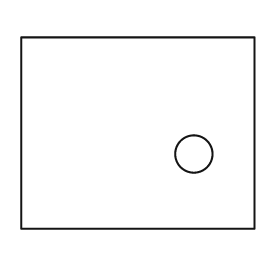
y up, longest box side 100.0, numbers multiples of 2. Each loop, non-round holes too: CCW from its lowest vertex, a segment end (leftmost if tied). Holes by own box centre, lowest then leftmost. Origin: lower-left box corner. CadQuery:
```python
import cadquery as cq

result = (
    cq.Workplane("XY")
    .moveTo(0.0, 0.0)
    .lineTo(100.0, 0.0)
    .lineTo(100.0, 82.0)
    .lineTo(0.0, 82.0)
    .close()
    .moveTo(74.0, 32.0)
    .circle(8.0)
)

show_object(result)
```